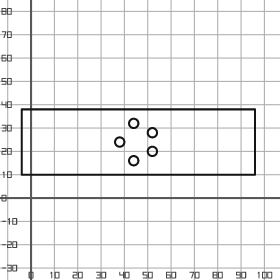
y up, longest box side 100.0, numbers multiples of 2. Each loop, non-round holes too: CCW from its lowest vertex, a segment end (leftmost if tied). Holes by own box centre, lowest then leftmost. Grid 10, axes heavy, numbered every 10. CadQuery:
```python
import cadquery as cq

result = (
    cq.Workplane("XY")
    .moveTo(-4.0, 10.0)
    .lineTo(96.0, 10.0)
    .lineTo(96.0, 38.0)
    .lineTo(-4.0, 38.0)
    .close()
    .moveTo(44.0, 16.0)
    .circle(2.0)
    .moveTo(52.0, 20.0)
    .circle(2.0)
    .moveTo(38.0, 24.0)
    .circle(2.0)
    .moveTo(52.0, 28.0)
    .circle(2.0)
    .moveTo(44.0, 32.0)
    .circle(2.0)
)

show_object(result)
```